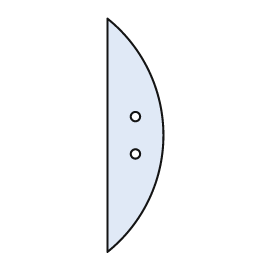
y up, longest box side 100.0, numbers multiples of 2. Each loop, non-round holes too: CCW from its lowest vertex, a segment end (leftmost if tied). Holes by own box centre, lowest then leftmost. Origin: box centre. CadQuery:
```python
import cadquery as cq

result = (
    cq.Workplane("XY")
    .moveTo(-12.0, -50.0)
    .threePointArc((12.0, 0.0), (-12.0, 50.0))
    .close()
    .moveTo(0.0, -8.0)
    .circle(2.0)
    .moveTo(0.0, 8.0)
    .circle(2.0)
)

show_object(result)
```